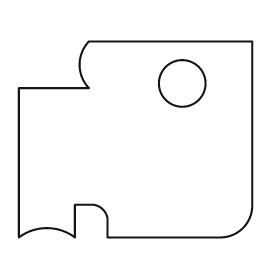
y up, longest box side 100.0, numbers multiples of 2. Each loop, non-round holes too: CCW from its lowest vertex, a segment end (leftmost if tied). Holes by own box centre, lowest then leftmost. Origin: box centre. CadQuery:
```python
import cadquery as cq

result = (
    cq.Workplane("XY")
    .moveTo(-50.0, -42.0)
    .threePointArc((-38.0, -38.0), (-26.0, -42.0))
    .lineTo(-26.0, -28.0)
    .lineTo(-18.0, -28.0)
    .threePointArc((-14.0, -30.0), (-12.0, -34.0))
    .lineTo(-12.0, -42.0)
    .lineTo(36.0, -42.0)
    .threePointArc((46.0, -38.0), (50.0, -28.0))
    .lineTo(50.0, 42.0)
    .lineTo(-20.0, 42.0)
    .threePointArc((-24.0, 32.0), (-20.0, 22.0))
    .lineTo(-50.0, 22.0)
    .close()
    .moveTo(20.0, 24.0)
    .circle(10.0)
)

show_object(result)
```